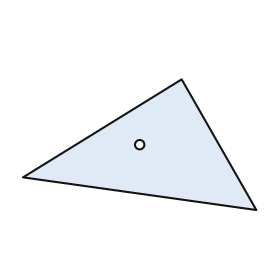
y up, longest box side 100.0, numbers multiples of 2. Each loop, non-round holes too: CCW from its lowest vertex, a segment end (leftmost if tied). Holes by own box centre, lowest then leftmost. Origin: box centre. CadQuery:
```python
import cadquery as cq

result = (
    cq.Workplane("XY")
    .moveTo(50.0, -28.0)
    .lineTo(18.0, 28.0)
    .lineTo(-50.0, -14.0)
    .close()
    .moveTo(0.0, 0.0)
    .circle(2.0)
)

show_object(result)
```